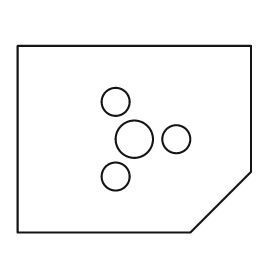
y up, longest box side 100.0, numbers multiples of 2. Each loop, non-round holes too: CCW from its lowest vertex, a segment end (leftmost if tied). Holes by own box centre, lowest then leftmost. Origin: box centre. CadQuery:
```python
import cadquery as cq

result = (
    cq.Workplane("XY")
    .moveTo(-50.0, -40.0)
    .lineTo(24.0, -40.0)
    .lineTo(50.0, -14.0)
    .lineTo(50.0, 40.0)
    .lineTo(-50.0, 40.0)
    .close()
    .moveTo(-8.0, -16.0)
    .circle(6.0)
    .moveTo(0.0, 0.0)
    .circle(8.0)
    .moveTo(18.0, 0.0)
    .circle(6.0)
    .moveTo(-8.0, 16.0)
    .circle(6.0)
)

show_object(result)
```